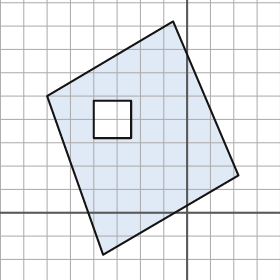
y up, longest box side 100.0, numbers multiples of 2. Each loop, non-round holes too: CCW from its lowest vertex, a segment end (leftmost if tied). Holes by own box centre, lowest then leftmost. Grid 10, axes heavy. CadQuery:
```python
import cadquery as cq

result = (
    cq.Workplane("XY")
    .moveTo(-36.0, -18.0)
    .lineTo(22.0, 16.0)
    .lineTo(-6.0, 82.0)
    .lineTo(-60.0, 50.0)
    .close()
    .moveTo(-40.0, 32.0)
    .lineTo(-24.0, 32.0)
    .lineTo(-24.0, 48.0)
    .lineTo(-40.0, 48.0)
    .close()
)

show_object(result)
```